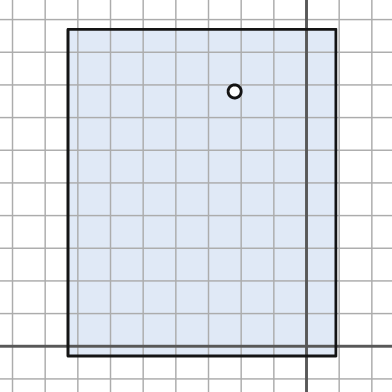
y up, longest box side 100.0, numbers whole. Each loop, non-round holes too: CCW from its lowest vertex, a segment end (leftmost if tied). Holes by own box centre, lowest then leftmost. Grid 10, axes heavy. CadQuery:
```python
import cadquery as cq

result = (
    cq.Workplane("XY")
    .moveTo(-73.0, -3.0)
    .lineTo(9.0, -3.0)
    .lineTo(9.0, 97.0)
    .lineTo(-73.0, 97.0)
    .close()
    .moveTo(-22.0, 78.0)
    .circle(2.0)
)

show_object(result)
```